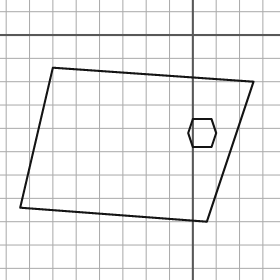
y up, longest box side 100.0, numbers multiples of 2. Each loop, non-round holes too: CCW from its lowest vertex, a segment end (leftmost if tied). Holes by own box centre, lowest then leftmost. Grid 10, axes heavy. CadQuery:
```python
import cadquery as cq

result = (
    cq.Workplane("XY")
    .moveTo(6.0, -80.0)
    .lineTo(26.0, -20.0)
    .lineTo(-60.0, -14.0)
    .lineTo(-74.0, -74.0)
    .close()
    .moveTo(0.0, -48.0)
    .lineTo(8.0, -48.0)
    .lineTo(10.0, -42.0)
    .lineTo(8.0, -36.0)
    .lineTo(0.0, -36.0)
    .lineTo(-2.0, -42.0)
    .close()
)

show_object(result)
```